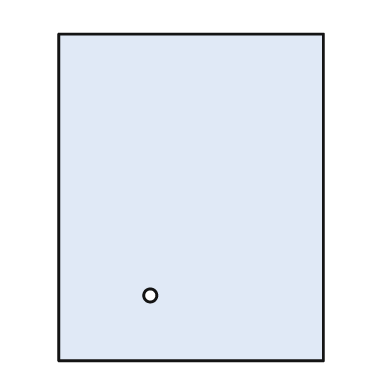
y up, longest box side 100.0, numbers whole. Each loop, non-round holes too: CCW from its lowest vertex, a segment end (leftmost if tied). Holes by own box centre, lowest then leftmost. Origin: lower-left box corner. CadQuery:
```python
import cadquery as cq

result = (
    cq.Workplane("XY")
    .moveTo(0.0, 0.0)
    .lineTo(81.0, 0.0)
    .lineTo(81.0, 100.0)
    .lineTo(0.0, 100.0)
    .close()
    .moveTo(28.0, 20.0)
    .circle(2.0)
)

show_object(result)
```